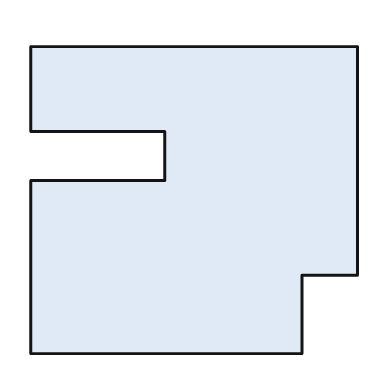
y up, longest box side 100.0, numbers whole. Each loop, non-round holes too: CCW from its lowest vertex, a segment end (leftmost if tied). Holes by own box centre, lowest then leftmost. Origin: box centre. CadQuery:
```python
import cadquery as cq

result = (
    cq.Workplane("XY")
    .moveTo(-50.0, -47.0)
    .lineTo(33.0, -47.0)
    .lineTo(33.0, -23.0)
    .lineTo(50.0, -23.0)
    .lineTo(50.0, 47.0)
    .lineTo(-50.0, 47.0)
    .lineTo(-50.0, 21.0)
    .lineTo(-9.0, 21.0)
    .lineTo(-9.0, 6.0)
    .lineTo(-50.0, 6.0)
    .close()
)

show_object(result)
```